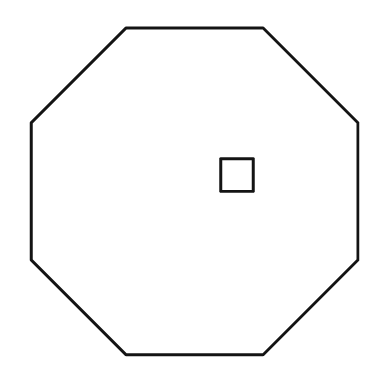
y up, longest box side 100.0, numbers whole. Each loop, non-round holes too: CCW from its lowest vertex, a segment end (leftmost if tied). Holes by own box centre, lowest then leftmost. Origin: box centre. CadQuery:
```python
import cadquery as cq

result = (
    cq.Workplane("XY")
    .moveTo(-21.0, -50.0)
    .lineTo(21.0, -50.0)
    .lineTo(50.0, -21.0)
    .lineTo(50.0, 21.0)
    .lineTo(21.0, 50.0)
    .lineTo(-21.0, 50.0)
    .lineTo(-50.0, 21.0)
    .lineTo(-50.0, -21.0)
    .close()
    .moveTo(8.0, 0.0)
    .lineTo(18.0, 0.0)
    .lineTo(18.0, 10.0)
    .lineTo(8.0, 10.0)
    .close()
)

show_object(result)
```